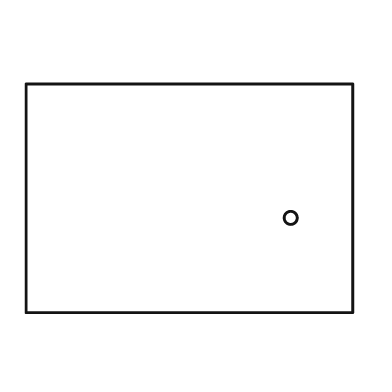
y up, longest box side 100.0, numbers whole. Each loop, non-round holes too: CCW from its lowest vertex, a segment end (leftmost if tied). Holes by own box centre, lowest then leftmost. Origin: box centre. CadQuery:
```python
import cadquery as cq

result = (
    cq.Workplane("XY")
    .moveTo(-50.0, -35.0)
    .lineTo(50.0, -35.0)
    .lineTo(50.0, 35.0)
    .lineTo(-50.0, 35.0)
    .close()
    .moveTo(31.0, -6.0)
    .circle(2.0)
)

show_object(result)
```